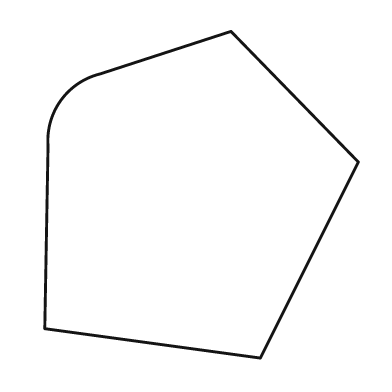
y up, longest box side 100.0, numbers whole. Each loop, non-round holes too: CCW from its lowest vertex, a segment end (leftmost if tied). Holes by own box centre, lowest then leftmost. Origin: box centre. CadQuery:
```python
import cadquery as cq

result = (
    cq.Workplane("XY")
    .moveTo(18.0, -50.0)
    .lineTo(48.0, 10.0)
    .lineTo(9.0, 50.0)
    .lineTo(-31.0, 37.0)
    .threePointArc((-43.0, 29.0), (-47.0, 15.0))
    .lineTo(-48.0, -41.0)
    .close()
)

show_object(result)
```